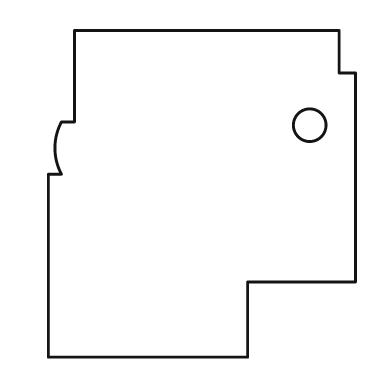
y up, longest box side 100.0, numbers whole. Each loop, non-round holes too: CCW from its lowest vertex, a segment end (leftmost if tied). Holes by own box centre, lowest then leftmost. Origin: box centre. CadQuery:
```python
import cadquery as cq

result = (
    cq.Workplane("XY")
    .moveTo(-47.0, -50.0)
    .lineTo(14.0, -50.0)
    .lineTo(14.0, -27.0)
    .lineTo(47.0, -27.0)
    .lineTo(47.0, 37.0)
    .lineTo(42.0, 37.0)
    .lineTo(42.0, 50.0)
    .lineTo(-39.0, 50.0)
    .lineTo(-39.0, 22.0)
    .lineTo(-43.0, 22.0)
    .threePointArc((-45.0, 14.0), (-43.0, 6.0))
    .lineTo(-47.0, 6.0)
    .close()
    .moveTo(33.0, 21.0)
    .circle(5.0)
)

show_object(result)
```